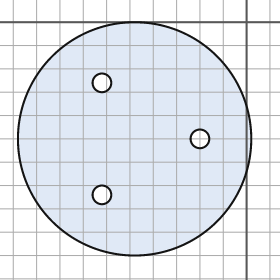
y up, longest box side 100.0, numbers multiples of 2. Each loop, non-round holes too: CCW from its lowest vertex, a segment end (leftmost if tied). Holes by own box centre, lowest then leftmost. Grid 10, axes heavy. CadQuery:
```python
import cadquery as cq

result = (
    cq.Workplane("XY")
    .moveTo(-48.0, -50.0)
    .circle(50.0)
    .moveTo(-62.0, -74.0)
    .circle(4.0)
    .moveTo(-20.0, -50.0)
    .circle(4.0)
    .moveTo(-62.0, -26.0)
    .circle(4.0)
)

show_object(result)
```